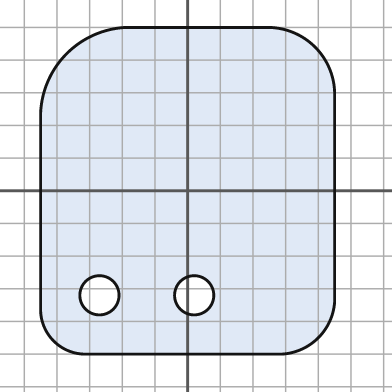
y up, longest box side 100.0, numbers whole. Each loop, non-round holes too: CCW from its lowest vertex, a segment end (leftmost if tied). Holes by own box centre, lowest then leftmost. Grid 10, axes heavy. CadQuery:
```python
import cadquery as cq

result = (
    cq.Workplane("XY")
    .moveTo(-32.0, -50.0)
    .lineTo(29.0, -50.0)
    .threePointArc((40.0, -45.0), (45.0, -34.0))
    .lineTo(45.0, 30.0)
    .threePointArc((39.0, 44.0), (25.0, 50.0))
    .lineTo(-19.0, 50.0)
    .threePointArc((-37.0, 42.0), (-45.0, 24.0))
    .lineTo(-45.0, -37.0)
    .threePointArc((-41.0, -46.0), (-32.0, -50.0))
    .close()
    .moveTo(-27.0, -32.0)
    .circle(6.0)
    .moveTo(2.0, -32.0)
    .circle(6.0)
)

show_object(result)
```